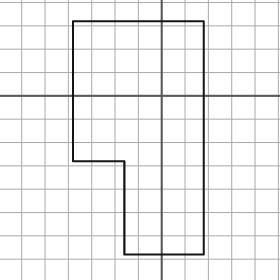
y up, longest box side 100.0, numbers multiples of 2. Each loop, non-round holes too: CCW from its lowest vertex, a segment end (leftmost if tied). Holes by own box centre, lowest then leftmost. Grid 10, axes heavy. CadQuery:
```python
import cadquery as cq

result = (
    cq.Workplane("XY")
    .moveTo(-16.0, -68.0)
    .lineTo(18.0, -68.0)
    .lineTo(18.0, 32.0)
    .lineTo(-38.0, 32.0)
    .lineTo(-38.0, -28.0)
    .lineTo(-16.0, -28.0)
    .close()
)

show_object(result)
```